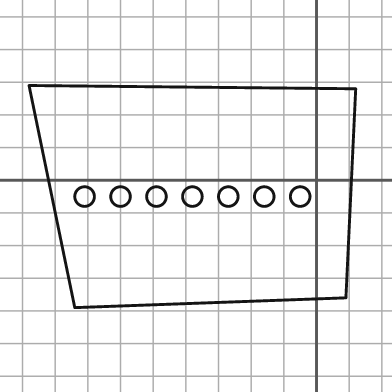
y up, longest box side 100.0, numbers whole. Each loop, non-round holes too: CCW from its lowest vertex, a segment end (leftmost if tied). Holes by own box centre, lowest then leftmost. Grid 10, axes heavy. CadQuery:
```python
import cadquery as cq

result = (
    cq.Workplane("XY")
    .moveTo(-74.0, -39.0)
    .lineTo(9.0, -36.0)
    .lineTo(12.0, 28.0)
    .lineTo(-88.0, 29.0)
    .close()
    .moveTo(-71.0, -5.0)
    .circle(3.0)
    .moveTo(-60.0, -5.0)
    .circle(3.0)
    .moveTo(-49.0, -5.0)
    .circle(3.0)
    .moveTo(-38.0, -5.0)
    .circle(3.0)
    .moveTo(-27.0, -5.0)
    .circle(3.0)
    .moveTo(-16.0, -5.0)
    .circle(3.0)
    .moveTo(-5.0, -5.0)
    .circle(3.0)
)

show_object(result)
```